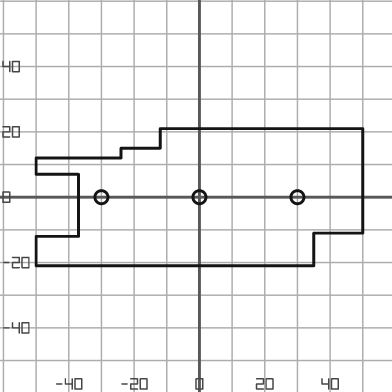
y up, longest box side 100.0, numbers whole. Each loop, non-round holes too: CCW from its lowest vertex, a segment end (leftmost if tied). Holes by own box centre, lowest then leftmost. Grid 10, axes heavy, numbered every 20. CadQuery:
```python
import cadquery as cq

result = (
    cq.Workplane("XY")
    .moveTo(-50.0, -21.0)
    .lineTo(35.0, -21.0)
    .lineTo(35.0, -11.0)
    .lineTo(50.0, -11.0)
    .lineTo(50.0, 21.0)
    .lineTo(-12.0, 21.0)
    .lineTo(-12.0, 15.0)
    .lineTo(-24.0, 15.0)
    .lineTo(-24.0, 12.0)
    .lineTo(-50.0, 12.0)
    .lineTo(-50.0, 7.0)
    .lineTo(-37.0, 7.0)
    .lineTo(-37.0, -12.0)
    .lineTo(-50.0, -12.0)
    .close()
    .moveTo(-30.0, 0.0)
    .circle(2.0)
    .moveTo(0.0, 0.0)
    .circle(2.0)
    .moveTo(30.0, 0.0)
    .circle(2.0)
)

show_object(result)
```